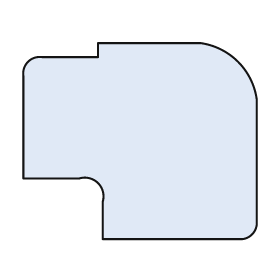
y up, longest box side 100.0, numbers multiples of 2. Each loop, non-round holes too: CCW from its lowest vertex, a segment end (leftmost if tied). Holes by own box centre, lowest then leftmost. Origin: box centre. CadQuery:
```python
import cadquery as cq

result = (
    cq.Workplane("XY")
    .moveTo(-16.0, -42.0)
    .lineTo(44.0, -42.0)
    .threePointArc((48.0, -40.0), (50.0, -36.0))
    .lineTo(50.0, 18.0)
    .threePointArc((42.0, 34.0), (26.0, 42.0))
    .lineTo(-18.0, 42.0)
    .lineTo(-18.0, 36.0)
    .lineTo(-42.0, 36.0)
    .threePointArc((-48.0, 34.0), (-50.0, 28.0))
    .lineTo(-50.0, -16.0)
    .lineTo(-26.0, -16.0)
    .threePointArc((-18.0, -18.0), (-16.0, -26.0))
    .close()
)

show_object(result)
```